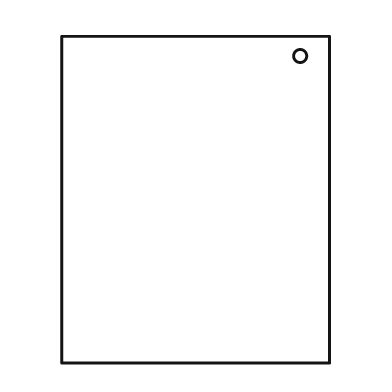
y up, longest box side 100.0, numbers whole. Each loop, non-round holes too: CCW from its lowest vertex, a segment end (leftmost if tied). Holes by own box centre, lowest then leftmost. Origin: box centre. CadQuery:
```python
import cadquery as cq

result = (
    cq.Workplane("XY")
    .moveTo(-41.0, -50.0)
    .lineTo(41.0, -50.0)
    .lineTo(41.0, 50.0)
    .lineTo(-41.0, 50.0)
    .close()
    .moveTo(32.0, 44.0)
    .circle(2.0)
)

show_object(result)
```